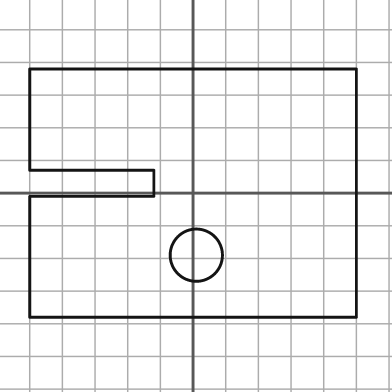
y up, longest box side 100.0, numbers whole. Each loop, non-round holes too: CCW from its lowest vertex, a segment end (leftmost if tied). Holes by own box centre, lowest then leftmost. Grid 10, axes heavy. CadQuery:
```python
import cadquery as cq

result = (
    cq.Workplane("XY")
    .moveTo(-50.0, -38.0)
    .lineTo(50.0, -38.0)
    .lineTo(50.0, 38.0)
    .lineTo(-50.0, 38.0)
    .lineTo(-50.0, 7.0)
    .lineTo(-12.0, 7.0)
    .lineTo(-12.0, -1.0)
    .lineTo(-50.0, -1.0)
    .close()
    .moveTo(1.0, -19.0)
    .circle(8.0)
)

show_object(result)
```